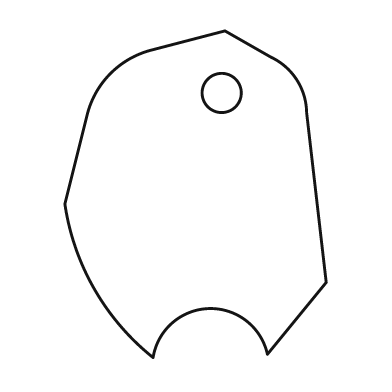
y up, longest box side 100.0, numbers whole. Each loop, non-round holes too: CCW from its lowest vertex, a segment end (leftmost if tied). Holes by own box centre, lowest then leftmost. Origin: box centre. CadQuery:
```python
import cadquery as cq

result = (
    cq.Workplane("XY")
    .moveTo(-13.0, -50.0)
    .threePointArc((4.0, -35.0), (22.0, -49.0))
    .lineTo(40.0, -27.0)
    .lineTo(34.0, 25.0)
    .threePointArc((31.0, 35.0), (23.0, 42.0))
    .lineTo(9.0, 50.0)
    .lineTo(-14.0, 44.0)
    .threePointArc((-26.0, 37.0), (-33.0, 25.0))
    .lineTo(-40.0, -3.0)
    .threePointArc((-31.0, -29.0), (-13.0, -50.0))
    .close()
    .moveTo(8.0, 31.0)
    .circle(6.0)
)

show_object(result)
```